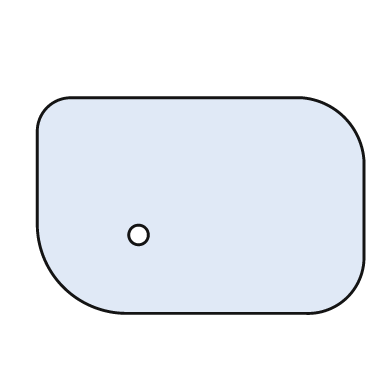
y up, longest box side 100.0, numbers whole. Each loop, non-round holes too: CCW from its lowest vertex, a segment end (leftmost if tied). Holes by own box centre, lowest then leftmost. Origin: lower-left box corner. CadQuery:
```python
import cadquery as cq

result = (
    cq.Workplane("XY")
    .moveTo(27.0, 0.0)
    .lineTo(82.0, 0.0)
    .threePointArc((95.0, 5.0), (100.0, 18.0))
    .lineTo(100.0, 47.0)
    .threePointArc((94.0, 60.0), (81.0, 66.0))
    .lineTo(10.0, 66.0)
    .threePointArc((3.0, 63.0), (0.0, 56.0))
    .lineTo(0.0, 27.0)
    .threePointArc((8.0, 8.0), (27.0, 0.0))
    .close()
    .moveTo(31.0, 24.0)
    .circle(3.0)
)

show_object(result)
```